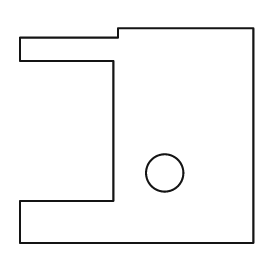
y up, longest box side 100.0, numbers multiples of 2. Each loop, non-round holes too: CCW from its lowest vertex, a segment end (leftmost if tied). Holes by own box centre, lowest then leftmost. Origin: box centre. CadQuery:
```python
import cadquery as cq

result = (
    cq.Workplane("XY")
    .moveTo(-50.0, -46.0)
    .lineTo(50.0, -46.0)
    .lineTo(50.0, 46.0)
    .lineTo(-8.0, 46.0)
    .lineTo(-8.0, 42.0)
    .lineTo(-50.0, 42.0)
    .lineTo(-50.0, 32.0)
    .lineTo(-10.0, 32.0)
    .lineTo(-10.0, -28.0)
    .lineTo(-50.0, -28.0)
    .close()
    .moveTo(12.0, -16.0)
    .circle(8.0)
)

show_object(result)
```